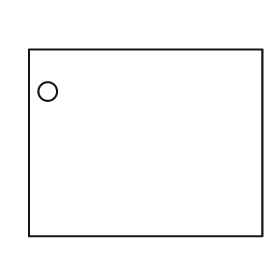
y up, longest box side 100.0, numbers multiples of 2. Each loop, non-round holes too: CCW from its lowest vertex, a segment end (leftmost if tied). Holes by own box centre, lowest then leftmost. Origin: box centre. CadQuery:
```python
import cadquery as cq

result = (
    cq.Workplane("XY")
    .moveTo(-50.0, -40.0)
    .lineTo(50.0, -40.0)
    .lineTo(50.0, 40.0)
    .lineTo(-50.0, 40.0)
    .close()
    .moveTo(-42.0, 22.0)
    .circle(4.0)
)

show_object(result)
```